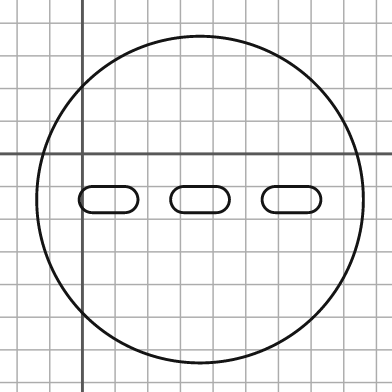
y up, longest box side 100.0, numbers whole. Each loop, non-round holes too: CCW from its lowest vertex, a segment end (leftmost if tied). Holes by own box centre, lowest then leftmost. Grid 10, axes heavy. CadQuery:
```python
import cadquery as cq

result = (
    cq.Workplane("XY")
    .moveTo(36.0, -14.0)
    .circle(50.0)
    .moveTo(3.0, -18.0)
    .lineTo(13.0, -18.0)
    .threePointArc((17.0, -14.0), (13.0, -10.0))
    .lineTo(3.0, -10.0)
    .threePointArc((-1.0, -14.0), (3.0, -18.0))
    .close()
    .moveTo(31.0, -18.0)
    .lineTo(41.0, -18.0)
    .threePointArc((45.0, -14.0), (41.0, -10.0))
    .lineTo(31.0, -10.0)
    .threePointArc((27.0, -14.0), (31.0, -18.0))
    .close()
    .moveTo(59.0, -18.0)
    .lineTo(69.0, -18.0)
    .threePointArc((73.0, -14.0), (69.0, -10.0))
    .lineTo(59.0, -10.0)
    .threePointArc((55.0, -14.0), (59.0, -18.0))
    .close()
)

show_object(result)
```